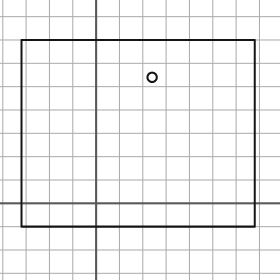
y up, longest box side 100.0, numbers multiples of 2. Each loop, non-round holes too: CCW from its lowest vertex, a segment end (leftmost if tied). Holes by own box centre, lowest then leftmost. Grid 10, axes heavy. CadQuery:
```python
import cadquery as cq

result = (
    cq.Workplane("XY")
    .moveTo(-32.0, -10.0)
    .lineTo(68.0, -10.0)
    .lineTo(68.0, 70.0)
    .lineTo(-32.0, 70.0)
    .close()
    .moveTo(24.0, 54.0)
    .circle(2.0)
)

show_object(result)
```